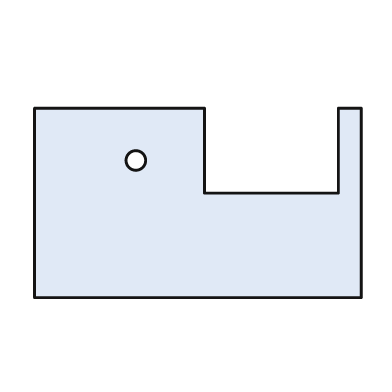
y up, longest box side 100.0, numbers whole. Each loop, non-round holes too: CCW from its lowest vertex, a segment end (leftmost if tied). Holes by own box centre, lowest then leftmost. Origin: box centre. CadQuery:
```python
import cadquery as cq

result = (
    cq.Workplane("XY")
    .moveTo(-50.0, -29.0)
    .lineTo(50.0, -29.0)
    .lineTo(50.0, 29.0)
    .lineTo(43.0, 29.0)
    .lineTo(43.0, 3.0)
    .lineTo(2.0, 3.0)
    .lineTo(2.0, 29.0)
    .lineTo(-50.0, 29.0)
    .close()
    .moveTo(-19.0, 13.0)
    .circle(3.0)
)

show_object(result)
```